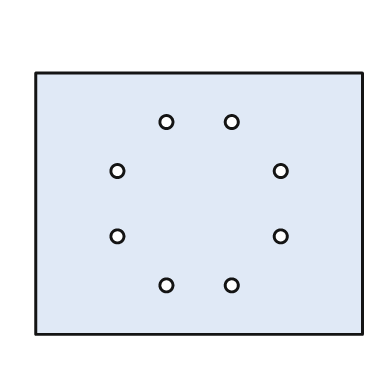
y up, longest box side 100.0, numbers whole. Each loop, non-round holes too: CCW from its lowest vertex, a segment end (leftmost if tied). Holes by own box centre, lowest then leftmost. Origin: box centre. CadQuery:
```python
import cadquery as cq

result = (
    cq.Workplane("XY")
    .moveTo(-50.0, -40.0)
    .lineTo(50.0, -40.0)
    .lineTo(50.0, 40.0)
    .lineTo(-50.0, 40.0)
    .close()
    .moveTo(-10.0, -25.0)
    .circle(2.0)
    .moveTo(10.0, -25.0)
    .circle(2.0)
    .moveTo(-25.0, -10.0)
    .circle(2.0)
    .moveTo(25.0, -10.0)
    .circle(2.0)
    .moveTo(-25.0, 10.0)
    .circle(2.0)
    .moveTo(25.0, 10.0)
    .circle(2.0)
    .moveTo(-10.0, 25.0)
    .circle(2.0)
    .moveTo(10.0, 25.0)
    .circle(2.0)
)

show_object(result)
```